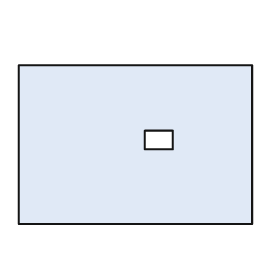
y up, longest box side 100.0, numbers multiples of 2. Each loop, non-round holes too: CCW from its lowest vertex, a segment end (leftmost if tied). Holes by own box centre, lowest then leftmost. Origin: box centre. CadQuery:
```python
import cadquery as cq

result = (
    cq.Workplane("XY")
    .moveTo(-50.0, -34.0)
    .lineTo(50.0, -34.0)
    .lineTo(50.0, 34.0)
    .lineTo(-50.0, 34.0)
    .close()
    .moveTo(4.0, -2.0)
    .lineTo(16.0, -2.0)
    .lineTo(16.0, 6.0)
    .lineTo(4.0, 6.0)
    .close()
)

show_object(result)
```